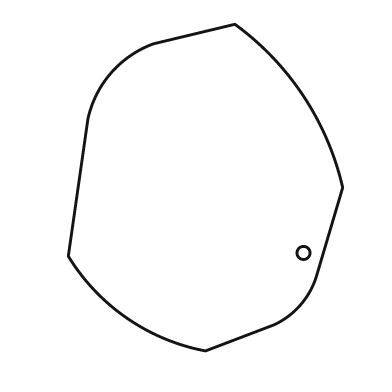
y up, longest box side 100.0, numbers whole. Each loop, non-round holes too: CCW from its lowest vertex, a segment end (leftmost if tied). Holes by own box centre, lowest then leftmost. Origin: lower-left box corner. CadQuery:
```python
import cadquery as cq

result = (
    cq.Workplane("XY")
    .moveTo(42.0, 0.0)
    .lineTo(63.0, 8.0)
    .threePointArc((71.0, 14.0), (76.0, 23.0))
    .lineTo(84.0, 50.0)
    .threePointArc((72.0, 78.0), (51.0, 100.0))
    .lineTo(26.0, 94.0)
    .threePointArc((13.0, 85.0), (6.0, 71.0))
    .lineTo(0.0, 29.0)
    .threePointArc((18.0, 10.0), (42.0, 0.0))
    .close()
    .moveTo(72.0, 30.0)
    .circle(2.0)
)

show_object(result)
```